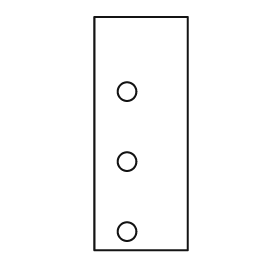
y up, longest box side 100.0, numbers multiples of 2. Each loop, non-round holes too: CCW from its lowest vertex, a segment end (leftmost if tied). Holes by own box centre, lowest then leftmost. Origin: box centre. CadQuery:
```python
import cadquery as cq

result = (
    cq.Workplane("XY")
    .moveTo(-20.0, -50.0)
    .lineTo(20.0, -50.0)
    .lineTo(20.0, 50.0)
    .lineTo(-20.0, 50.0)
    .close()
    .moveTo(-6.0, -42.0)
    .circle(4.0)
    .moveTo(-6.0, -12.0)
    .circle(4.0)
    .moveTo(-6.0, 18.0)
    .circle(4.0)
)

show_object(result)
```